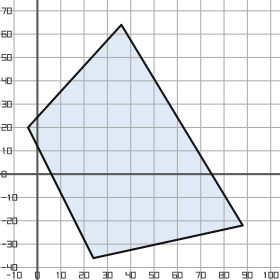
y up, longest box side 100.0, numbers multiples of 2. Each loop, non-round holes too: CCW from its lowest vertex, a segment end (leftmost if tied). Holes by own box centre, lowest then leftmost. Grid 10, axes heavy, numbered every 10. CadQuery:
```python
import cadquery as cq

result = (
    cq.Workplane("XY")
    .moveTo(24.0, -36.0)
    .lineTo(88.0, -22.0)
    .lineTo(36.0, 64.0)
    .lineTo(-4.0, 20.0)
    .close()
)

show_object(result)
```